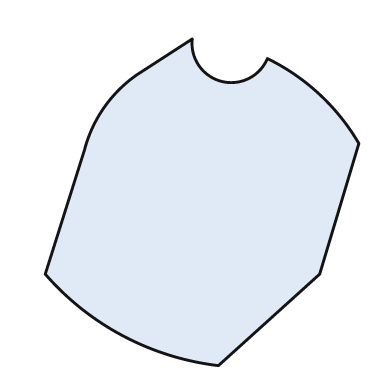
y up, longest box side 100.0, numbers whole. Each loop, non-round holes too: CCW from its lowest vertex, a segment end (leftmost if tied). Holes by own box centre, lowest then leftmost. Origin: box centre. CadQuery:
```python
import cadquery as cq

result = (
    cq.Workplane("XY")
    .moveTo(5.0, -50.0)
    .lineTo(36.0, -22.0)
    .lineTo(48.0, 18.0)
    .threePointArc((36.0, 33.0), (20.0, 44.0))
    .threePointArc((6.0, 37.0), (-3.0, 50.0))
    .lineTo(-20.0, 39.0)
    .threePointArc((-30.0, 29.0), (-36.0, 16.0))
    .lineTo(-48.0, -22.0)
    .threePointArc((-24.0, -41.0), (5.0, -50.0))
    .close()
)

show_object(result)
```